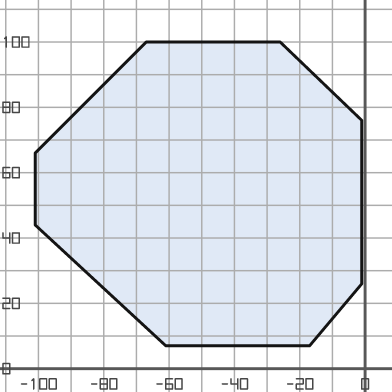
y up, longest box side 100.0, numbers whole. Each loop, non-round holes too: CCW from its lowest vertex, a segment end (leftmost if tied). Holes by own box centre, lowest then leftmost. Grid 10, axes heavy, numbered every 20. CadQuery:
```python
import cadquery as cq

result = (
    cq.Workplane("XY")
    .moveTo(-61.0, 7.0)
    .lineTo(-17.0, 7.0)
    .lineTo(-1.0, 26.0)
    .lineTo(-1.0, 76.0)
    .lineTo(-26.0, 100.0)
    .lineTo(-67.0, 100.0)
    .lineTo(-101.0, 66.0)
    .lineTo(-101.0, 44.0)
    .close()
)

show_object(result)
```